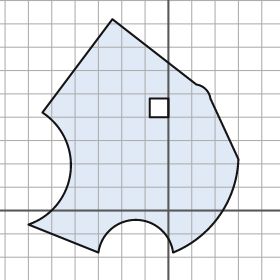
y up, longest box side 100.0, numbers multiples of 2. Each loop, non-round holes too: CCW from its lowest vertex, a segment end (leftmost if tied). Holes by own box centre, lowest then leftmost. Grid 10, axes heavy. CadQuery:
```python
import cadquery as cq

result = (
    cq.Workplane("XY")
    .moveTo(-30.0, -18.0)
    .threePointArc((-14.0, -4.0), (2.0, -18.0))
    .threePointArc((22.0, -2.0), (30.0, 22.0))
    .lineTo(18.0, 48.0)
    .threePointArc((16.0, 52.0), (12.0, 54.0))
    .lineTo(-24.0, 82.0)
    .lineTo(-54.0, 42.0)
    .threePointArc((-42.0, 16.0), (-60.0, -6.0))
    .close()
    .moveTo(-8.0, 40.0)
    .lineTo(0.0, 40.0)
    .lineTo(0.0, 48.0)
    .lineTo(-8.0, 48.0)
    .close()
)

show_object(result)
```